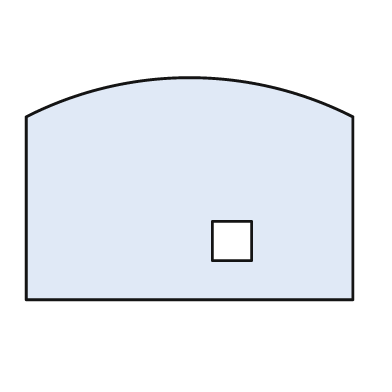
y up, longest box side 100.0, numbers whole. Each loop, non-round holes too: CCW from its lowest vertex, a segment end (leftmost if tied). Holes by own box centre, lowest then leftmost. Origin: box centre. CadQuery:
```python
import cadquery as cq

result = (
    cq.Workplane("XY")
    .moveTo(-50.0, -34.0)
    .lineTo(50.0, -34.0)
    .lineTo(50.0, 22.0)
    .threePointArc((0.0, 34.0), (-50.0, 22.0))
    .close()
    .moveTo(7.0, -22.0)
    .lineTo(19.0, -22.0)
    .lineTo(19.0, -10.0)
    .lineTo(7.0, -10.0)
    .close()
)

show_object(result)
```